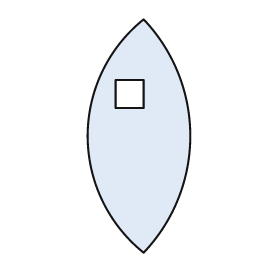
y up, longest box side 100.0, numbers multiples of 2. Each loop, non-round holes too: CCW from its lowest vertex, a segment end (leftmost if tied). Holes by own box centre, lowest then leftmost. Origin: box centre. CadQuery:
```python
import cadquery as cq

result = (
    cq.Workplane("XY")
    .moveTo(2.0, -50.0)
    .threePointArc((22.0, 0.0), (2.0, 50.0))
    .threePointArc((-22.0, 0.0), (2.0, -50.0))
    .close()
    .moveTo(-10.0, 12.0)
    .lineTo(2.0, 12.0)
    .lineTo(2.0, 24.0)
    .lineTo(-10.0, 24.0)
    .close()
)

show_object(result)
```